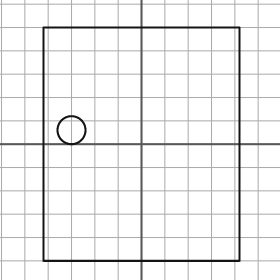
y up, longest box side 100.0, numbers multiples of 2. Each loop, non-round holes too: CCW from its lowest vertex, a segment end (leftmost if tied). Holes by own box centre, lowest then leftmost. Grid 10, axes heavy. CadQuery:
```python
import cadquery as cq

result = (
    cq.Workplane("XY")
    .moveTo(-42.0, -50.0)
    .lineTo(42.0, -50.0)
    .lineTo(42.0, 50.0)
    .lineTo(-42.0, 50.0)
    .close()
    .moveTo(-30.0, 6.0)
    .circle(6.0)
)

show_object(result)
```